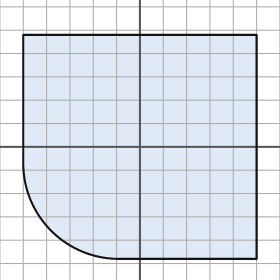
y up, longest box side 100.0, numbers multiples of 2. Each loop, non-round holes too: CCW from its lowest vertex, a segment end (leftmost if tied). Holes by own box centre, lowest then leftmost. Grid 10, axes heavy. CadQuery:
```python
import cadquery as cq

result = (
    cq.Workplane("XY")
    .moveTo(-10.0, -48.0)
    .lineTo(50.0, -48.0)
    .lineTo(50.0, 48.0)
    .lineTo(-50.0, 48.0)
    .lineTo(-50.0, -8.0)
    .threePointArc((-38.0, -36.0), (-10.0, -48.0))
    .close()
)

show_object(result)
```